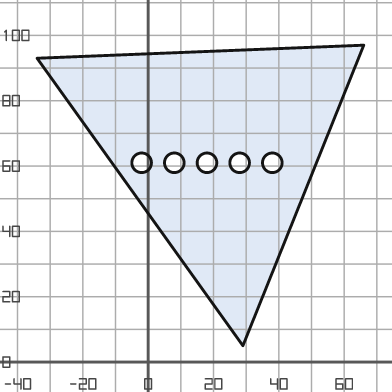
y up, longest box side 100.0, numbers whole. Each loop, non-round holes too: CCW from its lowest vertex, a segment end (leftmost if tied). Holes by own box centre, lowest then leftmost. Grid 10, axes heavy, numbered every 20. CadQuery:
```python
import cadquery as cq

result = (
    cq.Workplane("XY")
    .moveTo(29.0, 5.0)
    .lineTo(66.0, 97.0)
    .lineTo(-34.0, 93.0)
    .close()
    .moveTo(-2.0, 61.0)
    .circle(3.0)
    .moveTo(8.0, 61.0)
    .circle(3.0)
    .moveTo(18.0, 61.0)
    .circle(3.0)
    .moveTo(28.0, 61.0)
    .circle(3.0)
    .moveTo(38.0, 61.0)
    .circle(3.0)
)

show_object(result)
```